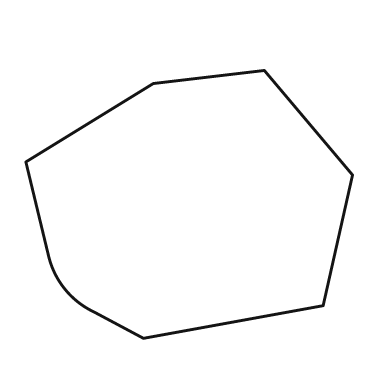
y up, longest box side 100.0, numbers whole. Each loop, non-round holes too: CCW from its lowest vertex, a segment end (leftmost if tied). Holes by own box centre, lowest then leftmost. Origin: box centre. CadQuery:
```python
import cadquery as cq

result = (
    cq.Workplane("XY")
    .moveTo(-14.0, -41.0)
    .lineTo(41.0, -31.0)
    .lineTo(50.0, 9.0)
    .lineTo(23.0, 41.0)
    .lineTo(-11.0, 37.0)
    .lineTo(-50.0, 13.0)
    .lineTo(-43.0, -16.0)
    .threePointArc((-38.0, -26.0), (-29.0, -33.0))
    .close()
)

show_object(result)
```